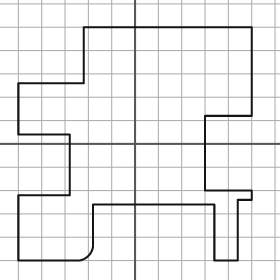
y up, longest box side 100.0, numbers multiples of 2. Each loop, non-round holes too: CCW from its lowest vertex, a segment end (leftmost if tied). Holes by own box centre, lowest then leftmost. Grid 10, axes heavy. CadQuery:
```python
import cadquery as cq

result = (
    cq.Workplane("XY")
    .moveTo(-50.0, -50.0)
    .lineTo(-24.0, -50.0)
    .threePointArc((-20.0, -48.0), (-18.0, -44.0))
    .lineTo(-18.0, -26.0)
    .lineTo(34.0, -26.0)
    .lineTo(34.0, -50.0)
    .lineTo(44.0, -50.0)
    .lineTo(44.0, -24.0)
    .lineTo(50.0, -24.0)
    .lineTo(50.0, -20.0)
    .lineTo(30.0, -20.0)
    .lineTo(30.0, 12.0)
    .lineTo(50.0, 12.0)
    .lineTo(50.0, 50.0)
    .lineTo(-22.0, 50.0)
    .lineTo(-22.0, 26.0)
    .lineTo(-50.0, 26.0)
    .lineTo(-50.0, 4.0)
    .lineTo(-28.0, 4.0)
    .lineTo(-28.0, -22.0)
    .lineTo(-50.0, -22.0)
    .close()
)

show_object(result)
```